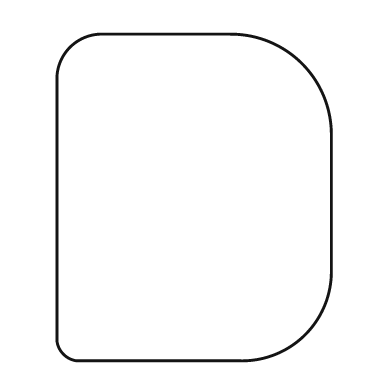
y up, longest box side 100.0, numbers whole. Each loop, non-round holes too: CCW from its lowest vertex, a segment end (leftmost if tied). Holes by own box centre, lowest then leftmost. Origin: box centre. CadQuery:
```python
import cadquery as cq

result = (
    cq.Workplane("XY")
    .moveTo(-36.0, -50.0)
    .lineTo(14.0, -50.0)
    .threePointArc((34.0, -42.0), (42.0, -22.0))
    .lineTo(42.0, 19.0)
    .threePointArc((33.0, 41.0), (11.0, 50.0))
    .lineTo(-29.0, 50.0)
    .threePointArc((-38.0, 46.0), (-42.0, 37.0))
    .lineTo(-42.0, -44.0)
    .threePointArc((-40.0, -48.0), (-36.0, -50.0))
    .close()
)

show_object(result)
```